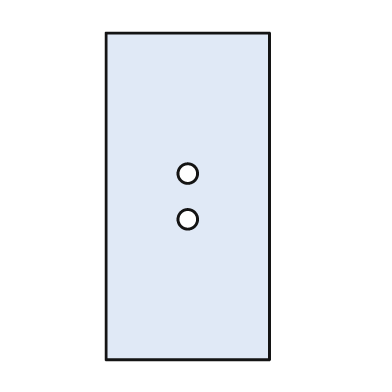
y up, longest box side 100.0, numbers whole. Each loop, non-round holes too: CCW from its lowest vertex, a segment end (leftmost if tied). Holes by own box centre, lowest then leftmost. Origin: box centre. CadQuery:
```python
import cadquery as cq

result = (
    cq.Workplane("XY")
    .moveTo(-25.0, -50.0)
    .lineTo(25.0, -50.0)
    .lineTo(25.0, 50.0)
    .lineTo(-25.0, 50.0)
    .close()
    .moveTo(0.0, -7.0)
    .circle(3.0)
    .moveTo(0.0, 7.0)
    .circle(3.0)
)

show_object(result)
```